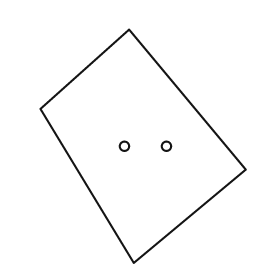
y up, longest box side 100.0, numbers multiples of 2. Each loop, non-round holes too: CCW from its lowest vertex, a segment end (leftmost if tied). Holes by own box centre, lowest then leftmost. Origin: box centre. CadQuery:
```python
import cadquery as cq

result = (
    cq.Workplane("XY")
    .moveTo(-4.0, -50.0)
    .lineTo(44.0, -10.0)
    .lineTo(-6.0, 50.0)
    .lineTo(-44.0, 16.0)
    .close()
    .moveTo(-8.0, 0.0)
    .circle(2.0)
    .moveTo(10.0, 0.0)
    .circle(2.0)
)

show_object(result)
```